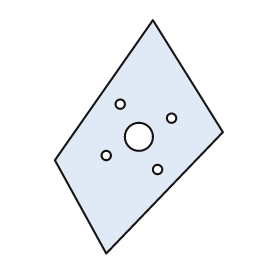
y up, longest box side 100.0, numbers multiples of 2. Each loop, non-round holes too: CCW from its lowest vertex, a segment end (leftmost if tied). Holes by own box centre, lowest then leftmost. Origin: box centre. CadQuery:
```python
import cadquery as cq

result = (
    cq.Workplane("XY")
    .moveTo(-14.0, -50.0)
    .lineTo(36.0, 2.0)
    .lineTo(6.0, 50.0)
    .lineTo(-36.0, -10.0)
    .close()
    .moveTo(8.0, -14.0)
    .circle(2.0)
    .moveTo(-14.0, -8.0)
    .circle(2.0)
    .moveTo(0.0, 0.0)
    .circle(6.0)
    .moveTo(14.0, 8.0)
    .circle(2.0)
    .moveTo(-8.0, 14.0)
    .circle(2.0)
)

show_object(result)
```